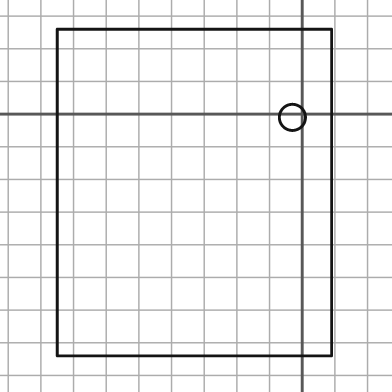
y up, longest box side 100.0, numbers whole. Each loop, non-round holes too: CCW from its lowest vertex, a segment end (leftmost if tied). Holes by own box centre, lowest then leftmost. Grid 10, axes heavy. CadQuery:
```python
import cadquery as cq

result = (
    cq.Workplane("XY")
    .moveTo(-75.0, -74.0)
    .lineTo(9.0, -74.0)
    .lineTo(9.0, 26.0)
    .lineTo(-75.0, 26.0)
    .close()
    .moveTo(-3.0, -1.0)
    .circle(4.0)
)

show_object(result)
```